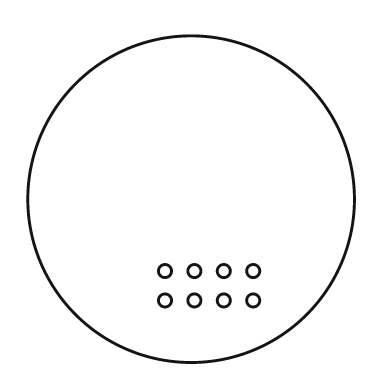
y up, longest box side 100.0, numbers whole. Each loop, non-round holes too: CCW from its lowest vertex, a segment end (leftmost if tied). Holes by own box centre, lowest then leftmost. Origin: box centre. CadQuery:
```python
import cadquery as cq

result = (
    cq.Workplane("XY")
    .moveTo(0.0, 0.0)
    .circle(50.0)
    .moveTo(-8.0, -31.0)
    .circle(2.0)
    .moveTo(1.0, -31.0)
    .circle(2.0)
    .moveTo(10.0, -31.0)
    .circle(2.0)
    .moveTo(19.0, -31.0)
    .circle(2.0)
    .moveTo(-8.0, -22.0)
    .circle(2.0)
    .moveTo(1.0, -22.0)
    .circle(2.0)
    .moveTo(10.0, -22.0)
    .circle(2.0)
    .moveTo(19.0, -22.0)
    .circle(2.0)
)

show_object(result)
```